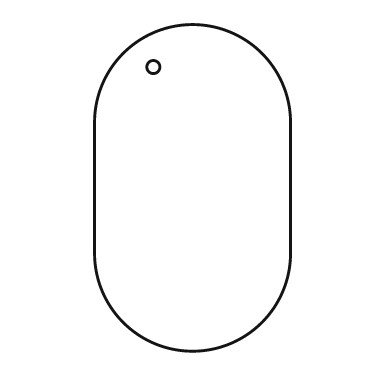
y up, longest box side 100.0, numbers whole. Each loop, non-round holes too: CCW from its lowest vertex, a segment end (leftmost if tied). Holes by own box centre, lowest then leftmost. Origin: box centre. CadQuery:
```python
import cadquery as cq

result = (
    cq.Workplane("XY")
    .moveTo(-30.0, -20.0)
    .threePointArc((0.0, -50.0), (30.0, -20.0))
    .lineTo(30.0, 20.0)
    .threePointArc((0.0, 50.0), (-30.0, 20.0))
    .close()
    .moveTo(-12.0, 37.0)
    .circle(2.0)
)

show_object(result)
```